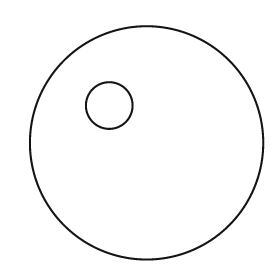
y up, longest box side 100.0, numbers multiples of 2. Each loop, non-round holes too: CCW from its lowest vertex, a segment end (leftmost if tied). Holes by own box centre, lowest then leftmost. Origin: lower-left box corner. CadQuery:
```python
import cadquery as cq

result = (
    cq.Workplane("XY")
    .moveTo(50.0, 50.0)
    .circle(50.0)
    .moveTo(34.0, 66.0)
    .circle(10.0)
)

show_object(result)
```